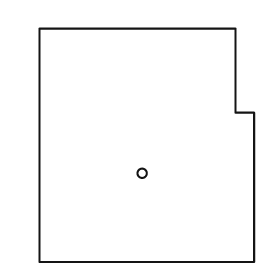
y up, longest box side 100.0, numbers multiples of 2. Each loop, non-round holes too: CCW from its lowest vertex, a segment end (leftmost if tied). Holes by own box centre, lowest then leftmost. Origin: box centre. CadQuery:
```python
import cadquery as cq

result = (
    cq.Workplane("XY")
    .moveTo(-46.0, -50.0)
    .lineTo(46.0, -50.0)
    .lineTo(46.0, 14.0)
    .lineTo(38.0, 14.0)
    .lineTo(38.0, 50.0)
    .lineTo(-46.0, 50.0)
    .close()
    .moveTo(-2.0, -12.0)
    .circle(2.0)
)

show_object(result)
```